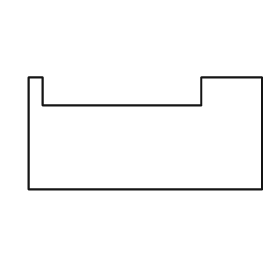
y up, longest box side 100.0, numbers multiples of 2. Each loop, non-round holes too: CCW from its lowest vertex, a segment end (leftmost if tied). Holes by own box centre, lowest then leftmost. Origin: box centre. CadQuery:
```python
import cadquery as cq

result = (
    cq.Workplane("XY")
    .moveTo(-50.0, -24.0)
    .lineTo(50.0, -24.0)
    .lineTo(50.0, 24.0)
    .lineTo(24.0, 24.0)
    .lineTo(24.0, 12.0)
    .lineTo(-44.0, 12.0)
    .lineTo(-44.0, 24.0)
    .lineTo(-50.0, 24.0)
    .close()
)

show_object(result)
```